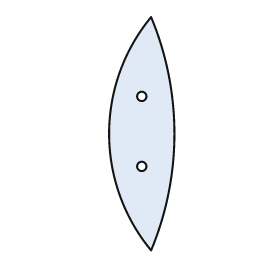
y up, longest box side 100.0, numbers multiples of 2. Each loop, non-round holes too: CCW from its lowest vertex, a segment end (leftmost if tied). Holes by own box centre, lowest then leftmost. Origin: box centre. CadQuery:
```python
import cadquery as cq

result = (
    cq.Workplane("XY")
    .moveTo(4.0, -50.0)
    .threePointArc((14.0, 0.0), (4.0, 50.0))
    .threePointArc((-14.0, 0.0), (4.0, -50.0))
    .close()
    .moveTo(0.0, -14.0)
    .circle(2.0)
    .moveTo(0.0, 16.0)
    .circle(2.0)
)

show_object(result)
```